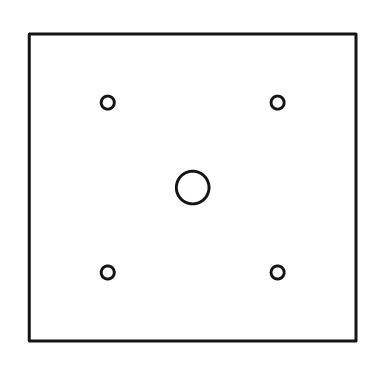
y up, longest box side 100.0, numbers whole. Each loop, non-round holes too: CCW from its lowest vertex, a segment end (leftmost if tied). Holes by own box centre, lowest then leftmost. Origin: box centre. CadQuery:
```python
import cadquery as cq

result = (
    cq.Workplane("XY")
    .moveTo(-50.0, -47.0)
    .lineTo(50.0, -47.0)
    .lineTo(50.0, 47.0)
    .lineTo(-50.0, 47.0)
    .close()
    .moveTo(-26.0, -26.0)
    .circle(2.0)
    .moveTo(26.0, -26.0)
    .circle(2.0)
    .moveTo(0.0, 0.0)
    .circle(5.0)
    .moveTo(-26.0, 26.0)
    .circle(2.0)
    .moveTo(26.0, 26.0)
    .circle(2.0)
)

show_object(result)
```